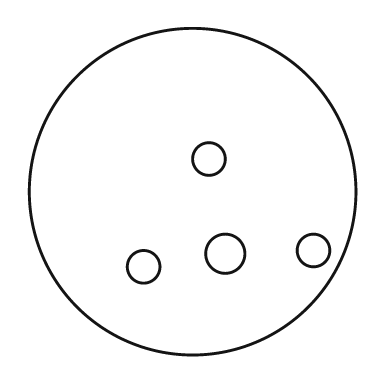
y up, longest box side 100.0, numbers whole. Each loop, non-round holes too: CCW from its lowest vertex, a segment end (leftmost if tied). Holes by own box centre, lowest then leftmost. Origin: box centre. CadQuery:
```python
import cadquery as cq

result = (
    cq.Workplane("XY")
    .moveTo(0.0, 0.0)
    .circle(50.0)
    .moveTo(-15.0, -23.0)
    .circle(5.0)
    .moveTo(10.0, -19.0)
    .circle(6.0)
    .moveTo(37.0, -18.0)
    .circle(5.0)
    .moveTo(5.0, 10.0)
    .circle(5.0)
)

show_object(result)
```